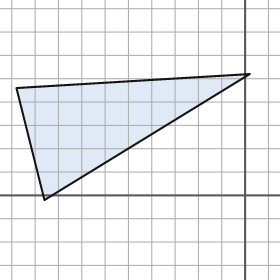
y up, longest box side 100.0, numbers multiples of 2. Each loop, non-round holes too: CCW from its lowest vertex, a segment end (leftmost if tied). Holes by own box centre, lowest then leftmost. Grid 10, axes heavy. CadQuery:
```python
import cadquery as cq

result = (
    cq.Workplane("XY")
    .moveTo(-86.0, -2.0)
    .lineTo(2.0, 52.0)
    .lineTo(-98.0, 46.0)
    .close()
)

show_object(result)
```